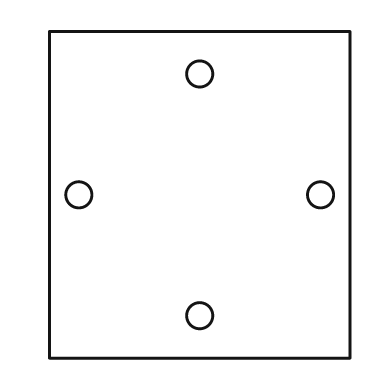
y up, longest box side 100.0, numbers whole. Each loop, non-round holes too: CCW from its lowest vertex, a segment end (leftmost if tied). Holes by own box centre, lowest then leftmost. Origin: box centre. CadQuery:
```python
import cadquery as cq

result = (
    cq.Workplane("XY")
    .moveTo(-46.0, -50.0)
    .lineTo(46.0, -50.0)
    .lineTo(46.0, 50.0)
    .lineTo(-46.0, 50.0)
    .close()
    .moveTo(0.0, -37.0)
    .circle(4.0)
    .moveTo(-37.0, 0.0)
    .circle(4.0)
    .moveTo(37.0, 0.0)
    .circle(4.0)
    .moveTo(0.0, 37.0)
    .circle(4.0)
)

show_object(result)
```